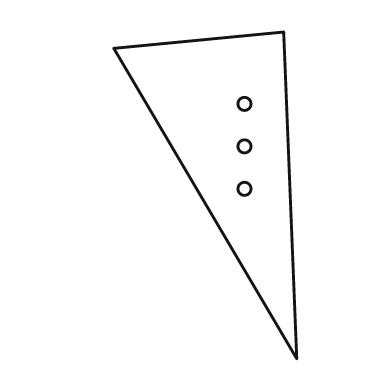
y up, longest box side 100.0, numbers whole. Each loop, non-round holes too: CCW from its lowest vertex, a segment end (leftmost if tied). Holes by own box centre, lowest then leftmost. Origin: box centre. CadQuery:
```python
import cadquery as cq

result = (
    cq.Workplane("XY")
    .moveTo(28.0, -50.0)
    .lineTo(24.0, 50.0)
    .lineTo(-28.0, 45.0)
    .close()
    .moveTo(12.0, 2.0)
    .circle(2.0)
    .moveTo(12.0, 15.0)
    .circle(2.0)
    .moveTo(12.0, 28.0)
    .circle(2.0)
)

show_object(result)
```